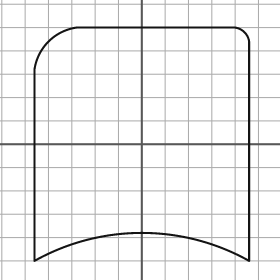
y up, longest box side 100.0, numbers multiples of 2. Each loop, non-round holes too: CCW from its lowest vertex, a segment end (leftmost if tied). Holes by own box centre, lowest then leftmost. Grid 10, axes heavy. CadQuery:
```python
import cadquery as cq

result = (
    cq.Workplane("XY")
    .moveTo(-46.0, -50.0)
    .threePointArc((0.0, -38.0), (46.0, -50.0))
    .lineTo(46.0, 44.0)
    .threePointArc((44.0, 48.0), (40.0, 50.0))
    .lineTo(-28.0, 50.0)
    .threePointArc((-40.0, 44.0), (-46.0, 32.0))
    .close()
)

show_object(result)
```